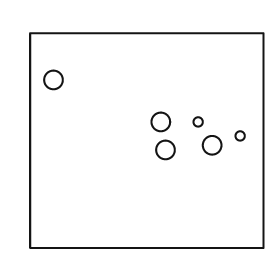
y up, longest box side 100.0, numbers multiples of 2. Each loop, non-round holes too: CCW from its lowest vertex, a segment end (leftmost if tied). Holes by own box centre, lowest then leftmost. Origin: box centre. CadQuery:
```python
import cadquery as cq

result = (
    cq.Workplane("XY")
    .moveTo(-50.0, -46.0)
    .lineTo(50.0, -46.0)
    .lineTo(50.0, 46.0)
    .lineTo(-50.0, 46.0)
    .close()
    .moveTo(8.0, -4.0)
    .circle(4.0)
    .moveTo(28.0, -2.0)
    .circle(4.0)
    .moveTo(40.0, 2.0)
    .circle(2.0)
    .moveTo(6.0, 8.0)
    .circle(4.0)
    .moveTo(22.0, 8.0)
    .circle(2.0)
    .moveTo(-40.0, 26.0)
    .circle(4.0)
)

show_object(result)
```